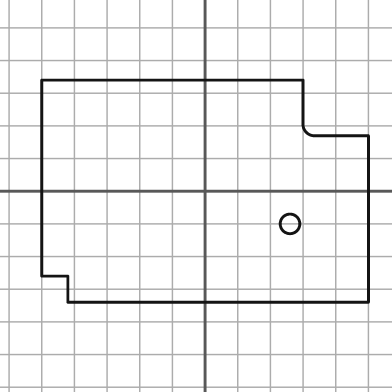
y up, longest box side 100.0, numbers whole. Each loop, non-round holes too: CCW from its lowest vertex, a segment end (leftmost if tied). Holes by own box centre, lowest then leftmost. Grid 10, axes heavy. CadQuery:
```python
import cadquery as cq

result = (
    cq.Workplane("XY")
    .moveTo(-42.0, -34.0)
    .lineTo(50.0, -34.0)
    .lineTo(50.0, 17.0)
    .lineTo(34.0, 17.0)
    .threePointArc((31.0, 18.0), (30.0, 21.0))
    .lineTo(30.0, 34.0)
    .lineTo(-50.0, 34.0)
    .lineTo(-50.0, -26.0)
    .lineTo(-42.0, -26.0)
    .close()
    .moveTo(26.0, -10.0)
    .circle(3.0)
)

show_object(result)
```